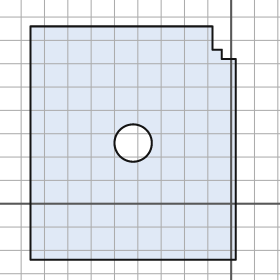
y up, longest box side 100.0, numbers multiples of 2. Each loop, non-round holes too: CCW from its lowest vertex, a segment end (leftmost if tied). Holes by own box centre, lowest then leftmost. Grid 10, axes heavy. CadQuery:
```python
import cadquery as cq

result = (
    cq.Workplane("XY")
    .moveTo(-86.0, -24.0)
    .lineTo(2.0, -24.0)
    .lineTo(2.0, 62.0)
    .lineTo(-4.0, 62.0)
    .lineTo(-4.0, 66.0)
    .lineTo(-8.0, 66.0)
    .lineTo(-8.0, 76.0)
    .lineTo(-86.0, 76.0)
    .close()
    .moveTo(-42.0, 26.0)
    .circle(8.0)
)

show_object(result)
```